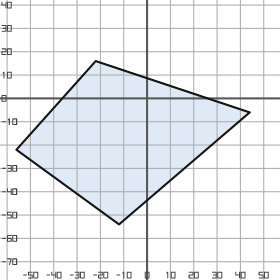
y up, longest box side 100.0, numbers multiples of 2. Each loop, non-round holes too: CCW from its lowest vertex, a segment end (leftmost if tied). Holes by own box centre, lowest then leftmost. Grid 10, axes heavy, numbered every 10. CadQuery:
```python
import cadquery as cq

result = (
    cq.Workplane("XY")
    .moveTo(-12.0, -54.0)
    .lineTo(44.0, -6.0)
    .lineTo(-22.0, 16.0)
    .lineTo(-56.0, -22.0)
    .close()
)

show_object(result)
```